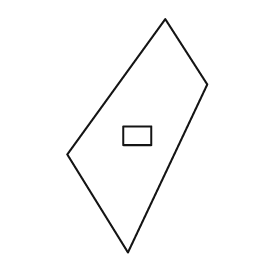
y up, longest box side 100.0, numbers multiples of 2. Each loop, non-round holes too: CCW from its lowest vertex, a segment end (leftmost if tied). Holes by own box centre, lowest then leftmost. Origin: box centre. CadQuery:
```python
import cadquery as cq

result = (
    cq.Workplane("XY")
    .moveTo(-4.0, -50.0)
    .lineTo(30.0, 22.0)
    .lineTo(12.0, 50.0)
    .lineTo(-30.0, -8.0)
    .close()
    .moveTo(-6.0, -4.0)
    .lineTo(6.0, -4.0)
    .lineTo(6.0, 4.0)
    .lineTo(-6.0, 4.0)
    .close()
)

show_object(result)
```